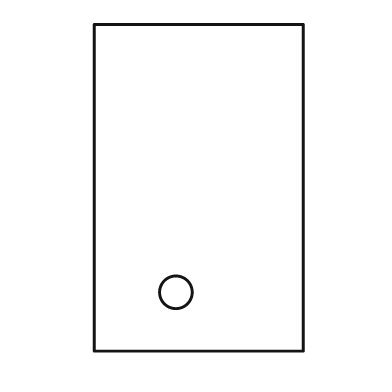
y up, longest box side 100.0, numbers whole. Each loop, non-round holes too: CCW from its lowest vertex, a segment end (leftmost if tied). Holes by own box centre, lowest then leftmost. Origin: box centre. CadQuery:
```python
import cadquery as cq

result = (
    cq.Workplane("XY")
    .moveTo(-32.0, -50.0)
    .lineTo(32.0, -50.0)
    .lineTo(32.0, 50.0)
    .lineTo(-32.0, 50.0)
    .close()
    .moveTo(-7.0, -32.0)
    .circle(5.0)
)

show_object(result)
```